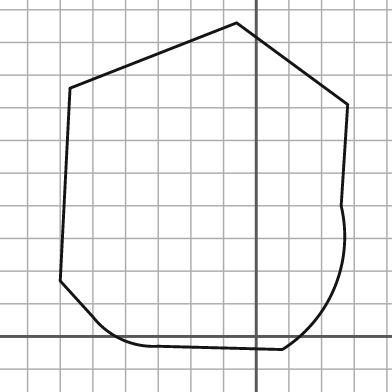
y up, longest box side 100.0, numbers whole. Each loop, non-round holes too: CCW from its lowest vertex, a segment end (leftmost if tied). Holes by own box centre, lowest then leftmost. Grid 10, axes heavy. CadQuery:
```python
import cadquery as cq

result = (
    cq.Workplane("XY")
    .moveTo(8.0, -4.0)
    .threePointArc((24.0, 15.0), (26.0, 40.0))
    .lineTo(28.0, 71.0)
    .lineTo(-6.0, 96.0)
    .lineTo(-57.0, 76.0)
    .lineTo(-60.0, 17.0)
    .lineTo(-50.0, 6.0)
    .threePointArc((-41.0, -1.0), (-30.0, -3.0))
    .close()
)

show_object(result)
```